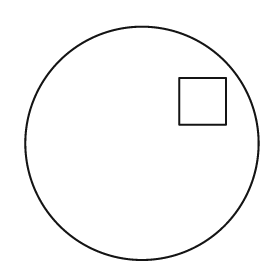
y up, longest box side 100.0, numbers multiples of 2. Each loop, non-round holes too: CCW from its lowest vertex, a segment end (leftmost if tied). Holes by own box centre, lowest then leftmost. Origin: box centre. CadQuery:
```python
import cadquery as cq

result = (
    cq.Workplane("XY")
    .moveTo(0.0, 0.0)
    .circle(50.0)
    .moveTo(16.0, 8.0)
    .lineTo(36.0, 8.0)
    .lineTo(36.0, 28.0)
    .lineTo(16.0, 28.0)
    .close()
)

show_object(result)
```